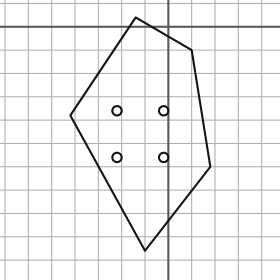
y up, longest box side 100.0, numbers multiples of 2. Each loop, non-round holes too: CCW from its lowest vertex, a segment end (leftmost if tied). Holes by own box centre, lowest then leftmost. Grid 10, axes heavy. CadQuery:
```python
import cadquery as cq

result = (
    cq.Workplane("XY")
    .moveTo(-10.0, -96.0)
    .lineTo(18.0, -60.0)
    .lineTo(10.0, -10.0)
    .lineTo(-14.0, 4.0)
    .lineTo(-42.0, -38.0)
    .close()
    .moveTo(-22.0, -56.0)
    .circle(2.0)
    .moveTo(-2.0, -56.0)
    .circle(2.0)
    .moveTo(-22.0, -36.0)
    .circle(2.0)
    .moveTo(-2.0, -36.0)
    .circle(2.0)
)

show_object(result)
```